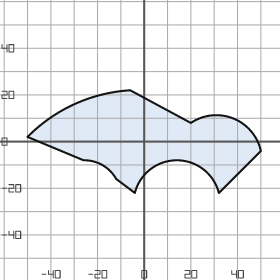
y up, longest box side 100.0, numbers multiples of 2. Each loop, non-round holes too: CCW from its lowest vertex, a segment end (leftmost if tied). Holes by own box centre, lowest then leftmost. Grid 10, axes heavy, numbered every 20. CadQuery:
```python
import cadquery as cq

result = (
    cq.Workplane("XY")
    .moveTo(-4.0, -22.0)
    .threePointArc((14.0, -8.0), (32.0, -22.0))
    .lineTo(50.0, -4.0)
    .threePointArc((38.0, 10.0), (20.0, 8.0))
    .lineTo(-6.0, 22.0)
    .threePointArc((-30.0, 16.0), (-50.0, 2.0))
    .lineTo(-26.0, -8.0)
    .threePointArc((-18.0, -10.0), (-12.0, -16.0))
    .close()
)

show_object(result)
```